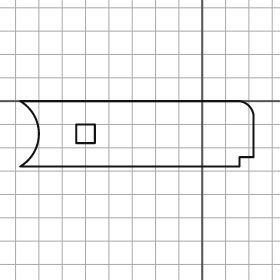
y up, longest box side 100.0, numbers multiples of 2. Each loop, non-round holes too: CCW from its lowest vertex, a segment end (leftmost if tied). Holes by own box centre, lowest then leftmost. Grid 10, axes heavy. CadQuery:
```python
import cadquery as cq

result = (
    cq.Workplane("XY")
    .moveTo(-78.0, -28.0)
    .lineTo(16.0, -28.0)
    .lineTo(16.0, -24.0)
    .lineTo(22.0, -24.0)
    .lineTo(22.0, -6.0)
    .threePointArc((20.0, -2.0), (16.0, 0.0))
    .lineTo(-78.0, 0.0)
    .threePointArc((-70.0, -14.0), (-78.0, -28.0))
    .close()
    .moveTo(-54.0, -18.0)
    .lineTo(-46.0, -18.0)
    .lineTo(-46.0, -10.0)
    .lineTo(-54.0, -10.0)
    .close()
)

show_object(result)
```